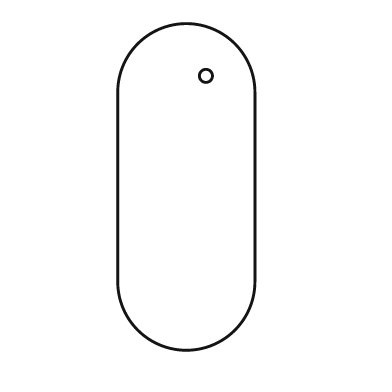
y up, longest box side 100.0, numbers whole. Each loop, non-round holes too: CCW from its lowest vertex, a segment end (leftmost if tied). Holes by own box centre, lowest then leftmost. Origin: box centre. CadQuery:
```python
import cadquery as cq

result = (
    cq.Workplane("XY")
    .moveTo(-21.0, -29.0)
    .threePointArc((0.0, -50.0), (21.0, -29.0))
    .lineTo(21.0, 29.0)
    .threePointArc((0.0, 50.0), (-21.0, 29.0))
    .close()
    .moveTo(6.0, 34.0)
    .circle(2.0)
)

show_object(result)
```